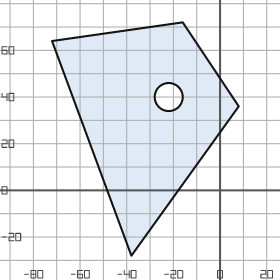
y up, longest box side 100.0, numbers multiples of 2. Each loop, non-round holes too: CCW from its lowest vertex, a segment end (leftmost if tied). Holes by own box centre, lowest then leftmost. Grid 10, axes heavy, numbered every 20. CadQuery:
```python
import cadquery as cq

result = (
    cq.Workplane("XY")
    .moveTo(-38.0, -28.0)
    .lineTo(8.0, 36.0)
    .lineTo(-16.0, 72.0)
    .lineTo(-72.0, 64.0)
    .close()
    .moveTo(-22.0, 40.0)
    .circle(6.0)
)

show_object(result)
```